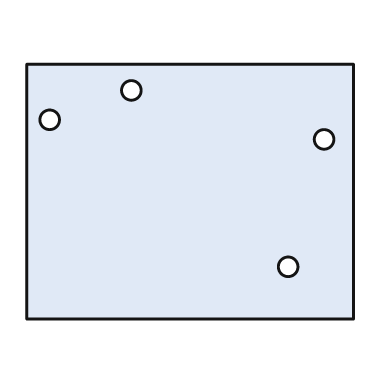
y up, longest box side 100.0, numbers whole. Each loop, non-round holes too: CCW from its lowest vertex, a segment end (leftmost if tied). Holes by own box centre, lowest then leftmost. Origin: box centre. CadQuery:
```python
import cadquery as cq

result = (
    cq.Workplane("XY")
    .moveTo(-50.0, -39.0)
    .lineTo(50.0, -39.0)
    .lineTo(50.0, 39.0)
    .lineTo(-50.0, 39.0)
    .close()
    .moveTo(30.0, -23.0)
    .circle(3.0)
    .moveTo(41.0, 16.0)
    .circle(3.0)
    .moveTo(-43.0, 22.0)
    .circle(3.0)
    .moveTo(-18.0, 31.0)
    .circle(3.0)
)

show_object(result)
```